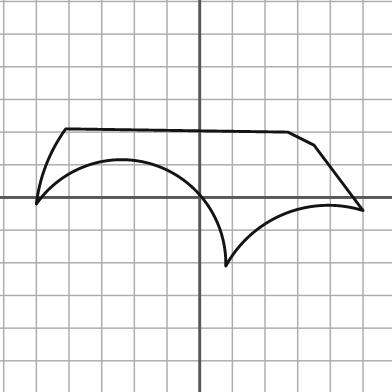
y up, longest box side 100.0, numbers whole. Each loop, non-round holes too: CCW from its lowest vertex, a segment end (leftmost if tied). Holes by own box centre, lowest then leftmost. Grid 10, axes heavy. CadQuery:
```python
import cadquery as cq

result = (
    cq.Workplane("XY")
    .moveTo(8.0, -21.0)
    .threePointArc((26.0, -5.0), (50.0, -4.0))
    .lineTo(35.0, 16.0)
    .lineTo(27.0, 20.0)
    .lineTo(-41.0, 21.0)
    .threePointArc((-47.0, 10.0), (-50.0, -2.0))
    .threePointArc((-14.0, 10.0), (8.0, -21.0))
    .close()
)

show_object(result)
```